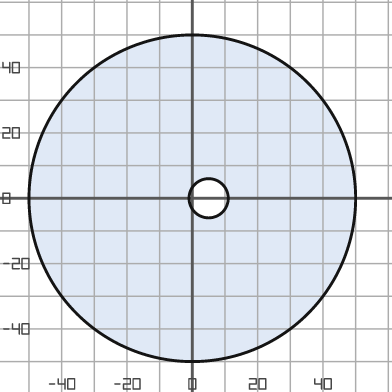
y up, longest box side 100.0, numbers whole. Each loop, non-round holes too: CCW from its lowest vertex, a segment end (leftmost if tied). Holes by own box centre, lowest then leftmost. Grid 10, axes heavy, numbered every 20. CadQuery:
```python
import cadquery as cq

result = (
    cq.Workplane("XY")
    .moveTo(0.0, 0.0)
    .circle(50.0)
    .moveTo(5.0, 0.0)
    .circle(6.0)
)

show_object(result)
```